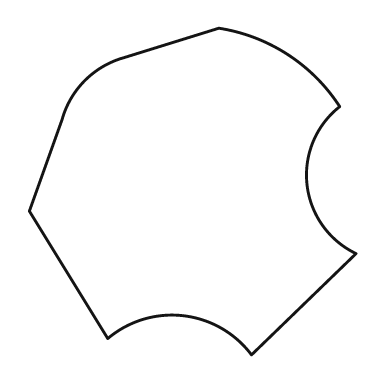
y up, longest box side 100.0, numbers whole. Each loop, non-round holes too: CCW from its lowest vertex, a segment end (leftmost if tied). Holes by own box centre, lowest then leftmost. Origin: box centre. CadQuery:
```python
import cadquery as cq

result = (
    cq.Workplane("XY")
    .moveTo(18.0, -50.0)
    .lineTo(50.0, -19.0)
    .threePointArc((35.0, 2.0), (45.0, 26.0))
    .threePointArc((29.0, 42.0), (8.0, 50.0))
    .lineTo(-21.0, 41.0)
    .threePointArc((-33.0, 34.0), (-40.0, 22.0))
    .lineTo(-50.0, -6.0)
    .lineTo(-26.0, -45.0)
    .threePointArc((-3.0, -38.0), (18.0, -50.0))
    .close()
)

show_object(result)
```